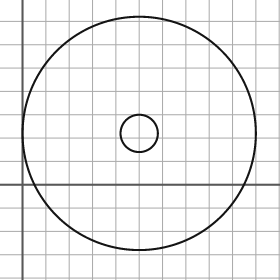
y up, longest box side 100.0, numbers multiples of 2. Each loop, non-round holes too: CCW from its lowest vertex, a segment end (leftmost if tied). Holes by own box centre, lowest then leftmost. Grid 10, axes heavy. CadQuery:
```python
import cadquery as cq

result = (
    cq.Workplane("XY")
    .moveTo(50.0, 22.0)
    .circle(50.0)
    .moveTo(50.0, 22.0)
    .circle(8.0)
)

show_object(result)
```